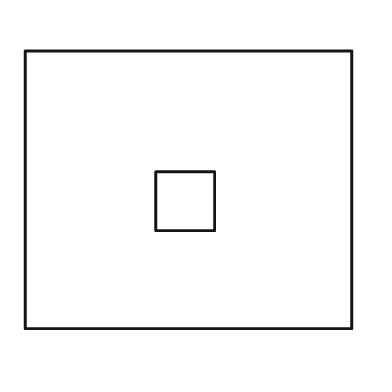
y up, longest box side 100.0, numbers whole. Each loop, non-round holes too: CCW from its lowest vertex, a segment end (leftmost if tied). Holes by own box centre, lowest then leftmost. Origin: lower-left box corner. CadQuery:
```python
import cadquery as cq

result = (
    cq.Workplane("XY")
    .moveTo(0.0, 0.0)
    .lineTo(100.0, 0.0)
    .lineTo(100.0, 85.0)
    .lineTo(0.0, 85.0)
    .close()
    .moveTo(40.0, 30.0)
    .lineTo(58.0, 30.0)
    .lineTo(58.0, 48.0)
    .lineTo(40.0, 48.0)
    .close()
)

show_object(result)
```